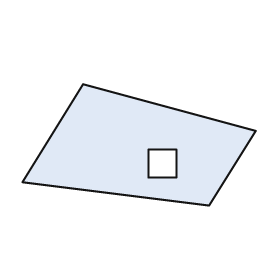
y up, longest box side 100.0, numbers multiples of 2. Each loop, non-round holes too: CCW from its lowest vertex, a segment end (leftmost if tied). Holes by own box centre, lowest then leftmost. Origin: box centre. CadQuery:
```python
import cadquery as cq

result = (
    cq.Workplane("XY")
    .moveTo(30.0, -26.0)
    .lineTo(50.0, 6.0)
    .lineTo(-24.0, 26.0)
    .lineTo(-50.0, -16.0)
    .close()
    .moveTo(4.0, -14.0)
    .lineTo(16.0, -14.0)
    .lineTo(16.0, -2.0)
    .lineTo(4.0, -2.0)
    .close()
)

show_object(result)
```